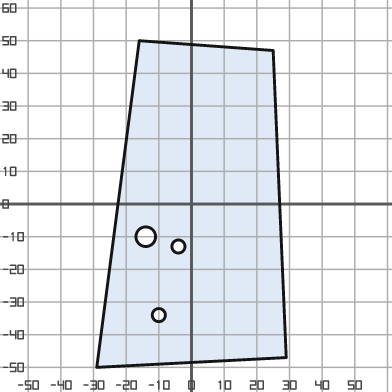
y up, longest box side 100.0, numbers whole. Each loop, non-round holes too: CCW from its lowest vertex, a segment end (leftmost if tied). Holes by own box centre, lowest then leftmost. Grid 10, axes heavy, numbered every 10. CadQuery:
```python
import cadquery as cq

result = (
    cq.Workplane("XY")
    .moveTo(-29.0, -50.0)
    .lineTo(29.0, -47.0)
    .lineTo(25.0, 47.0)
    .lineTo(-16.0, 50.0)
    .close()
    .moveTo(-10.0, -34.0)
    .circle(2.0)
    .moveTo(-4.0, -13.0)
    .circle(2.0)
    .moveTo(-14.0, -10.0)
    .circle(3.0)
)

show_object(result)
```